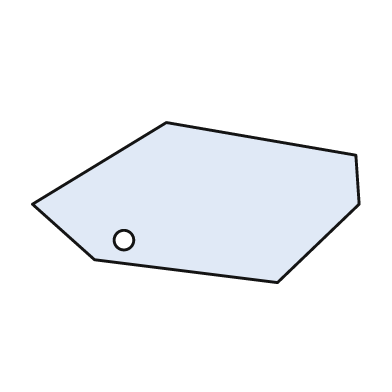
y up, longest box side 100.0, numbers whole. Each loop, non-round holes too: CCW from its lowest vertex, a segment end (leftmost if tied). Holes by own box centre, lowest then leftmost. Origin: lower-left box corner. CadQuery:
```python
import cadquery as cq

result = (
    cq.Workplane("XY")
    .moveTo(75.0, 0.0)
    .lineTo(100.0, 24.0)
    .lineTo(99.0, 39.0)
    .lineTo(41.0, 49.0)
    .lineTo(0.0, 24.0)
    .lineTo(19.0, 7.0)
    .close()
    .moveTo(28.0, 13.0)
    .circle(3.0)
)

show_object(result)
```